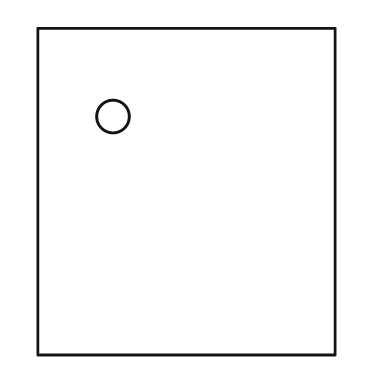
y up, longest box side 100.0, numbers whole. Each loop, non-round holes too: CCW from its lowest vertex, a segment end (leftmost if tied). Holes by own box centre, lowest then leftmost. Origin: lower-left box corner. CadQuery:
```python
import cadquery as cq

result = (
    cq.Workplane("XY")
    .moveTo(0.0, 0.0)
    .lineTo(91.0, 0.0)
    .lineTo(91.0, 100.0)
    .lineTo(0.0, 100.0)
    .close()
    .moveTo(23.0, 73.0)
    .circle(5.0)
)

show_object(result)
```